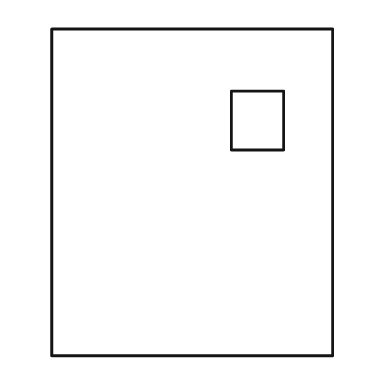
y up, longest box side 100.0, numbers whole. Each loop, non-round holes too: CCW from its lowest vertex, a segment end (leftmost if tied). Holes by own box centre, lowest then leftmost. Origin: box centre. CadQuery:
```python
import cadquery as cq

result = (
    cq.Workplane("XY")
    .moveTo(-43.0, -50.0)
    .lineTo(43.0, -50.0)
    .lineTo(43.0, 50.0)
    .lineTo(-43.0, 50.0)
    .close()
    .moveTo(12.0, 13.0)
    .lineTo(28.0, 13.0)
    .lineTo(28.0, 31.0)
    .lineTo(12.0, 31.0)
    .close()
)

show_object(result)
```